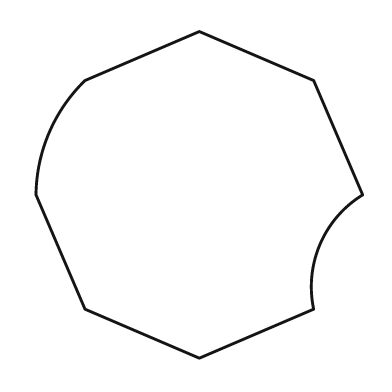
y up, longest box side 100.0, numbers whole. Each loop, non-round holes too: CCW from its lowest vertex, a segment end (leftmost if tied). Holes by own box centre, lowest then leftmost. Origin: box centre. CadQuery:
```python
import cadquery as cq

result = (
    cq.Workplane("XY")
    .moveTo(0.0, -50.0)
    .lineTo(35.0, -35.0)
    .threePointArc((37.0, -15.0), (50.0, 0.0))
    .lineTo(35.0, 35.0)
    .lineTo(0.0, 50.0)
    .lineTo(-35.0, 35.0)
    .threePointArc((-46.0, 19.0), (-50.0, 0.0))
    .lineTo(-35.0, -35.0)
    .close()
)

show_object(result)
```